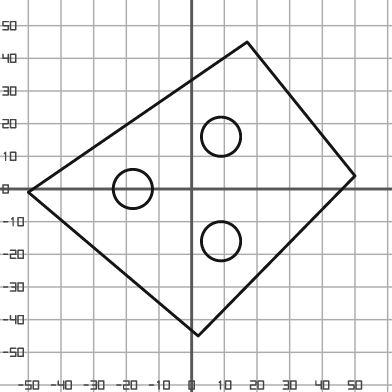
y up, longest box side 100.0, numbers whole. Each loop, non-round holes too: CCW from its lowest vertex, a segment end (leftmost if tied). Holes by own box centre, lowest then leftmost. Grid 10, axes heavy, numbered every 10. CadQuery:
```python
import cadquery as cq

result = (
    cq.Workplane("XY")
    .moveTo(2.0, -45.0)
    .lineTo(50.0, 4.0)
    .lineTo(17.0, 45.0)
    .lineTo(-50.0, -1.0)
    .close()
    .moveTo(9.0, -16.0)
    .circle(6.0)
    .moveTo(-18.0, 0.0)
    .circle(6.0)
    .moveTo(9.0, 16.0)
    .circle(6.0)
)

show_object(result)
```